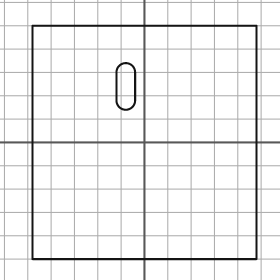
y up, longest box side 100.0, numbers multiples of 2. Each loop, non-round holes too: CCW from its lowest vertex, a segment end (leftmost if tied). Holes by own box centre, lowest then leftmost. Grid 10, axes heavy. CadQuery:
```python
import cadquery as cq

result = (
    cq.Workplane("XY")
    .moveTo(-48.0, -50.0)
    .lineTo(48.0, -50.0)
    .lineTo(48.0, 50.0)
    .lineTo(-48.0, 50.0)
    .close()
    .moveTo(-12.0, 18.0)
    .threePointArc((-8.0, 14.0), (-4.0, 18.0))
    .lineTo(-4.0, 30.0)
    .threePointArc((-8.0, 34.0), (-12.0, 30.0))
    .close()
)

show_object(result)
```